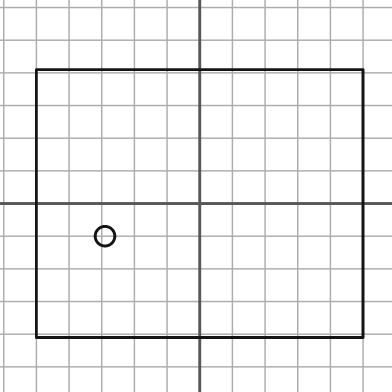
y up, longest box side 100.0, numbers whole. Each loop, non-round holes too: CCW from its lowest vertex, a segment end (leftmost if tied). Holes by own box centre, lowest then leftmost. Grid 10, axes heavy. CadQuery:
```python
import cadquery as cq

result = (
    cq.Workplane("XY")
    .moveTo(-50.0, -41.0)
    .lineTo(50.0, -41.0)
    .lineTo(50.0, 41.0)
    .lineTo(-50.0, 41.0)
    .close()
    .moveTo(-29.0, -10.0)
    .circle(3.0)
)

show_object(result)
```